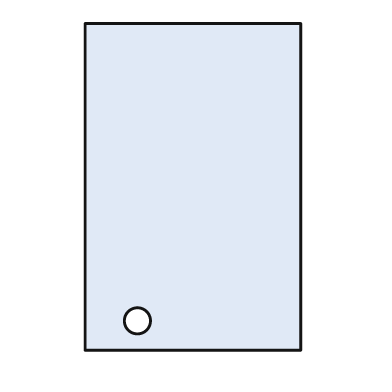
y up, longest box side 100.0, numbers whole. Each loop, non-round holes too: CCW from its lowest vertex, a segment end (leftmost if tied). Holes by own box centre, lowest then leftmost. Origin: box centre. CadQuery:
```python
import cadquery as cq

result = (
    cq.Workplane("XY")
    .moveTo(-33.0, -50.0)
    .lineTo(33.0, -50.0)
    .lineTo(33.0, 50.0)
    .lineTo(-33.0, 50.0)
    .close()
    .moveTo(-17.0, -41.0)
    .circle(4.0)
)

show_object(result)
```